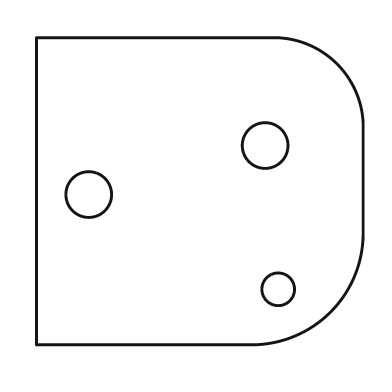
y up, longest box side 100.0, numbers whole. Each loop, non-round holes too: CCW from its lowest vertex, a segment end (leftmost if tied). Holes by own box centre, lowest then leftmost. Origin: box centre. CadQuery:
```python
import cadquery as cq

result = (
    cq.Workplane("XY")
    .moveTo(-50.0, -47.0)
    .lineTo(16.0, -47.0)
    .threePointArc((40.0, -37.0), (50.0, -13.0))
    .lineTo(50.0, 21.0)
    .threePointArc((42.0, 39.0), (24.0, 47.0))
    .lineTo(-50.0, 47.0)
    .close()
    .moveTo(24.0, -30.0)
    .circle(5.0)
    .moveTo(-34.0, -1.0)
    .circle(7.0)
    .moveTo(20.0, 14.0)
    .circle(7.0)
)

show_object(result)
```